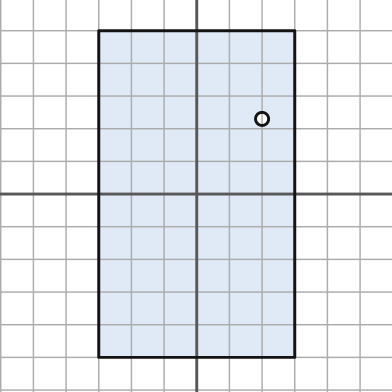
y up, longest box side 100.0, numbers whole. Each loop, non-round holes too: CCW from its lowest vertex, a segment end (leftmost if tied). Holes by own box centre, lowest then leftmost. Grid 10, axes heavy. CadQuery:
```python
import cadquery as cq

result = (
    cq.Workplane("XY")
    .moveTo(-30.0, -50.0)
    .lineTo(30.0, -50.0)
    .lineTo(30.0, 50.0)
    .lineTo(-30.0, 50.0)
    .close()
    .moveTo(20.0, 23.0)
    .circle(2.0)
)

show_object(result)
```